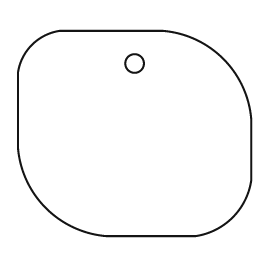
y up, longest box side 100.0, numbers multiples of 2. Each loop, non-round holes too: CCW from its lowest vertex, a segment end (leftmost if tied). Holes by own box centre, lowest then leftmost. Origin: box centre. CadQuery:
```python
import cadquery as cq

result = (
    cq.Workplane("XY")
    .moveTo(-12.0, -44.0)
    .lineTo(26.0, -44.0)
    .threePointArc((42.0, -36.0), (50.0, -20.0))
    .lineTo(50.0, 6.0)
    .threePointArc((38.0, 32.0), (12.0, 44.0))
    .lineTo(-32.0, 44.0)
    .threePointArc((-44.0, 38.0), (-50.0, 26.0))
    .lineTo(-50.0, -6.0)
    .threePointArc((-38.0, -32.0), (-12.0, -44.0))
    .close()
    .moveTo(0.0, 30.0)
    .circle(4.0)
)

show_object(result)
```